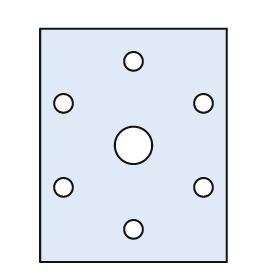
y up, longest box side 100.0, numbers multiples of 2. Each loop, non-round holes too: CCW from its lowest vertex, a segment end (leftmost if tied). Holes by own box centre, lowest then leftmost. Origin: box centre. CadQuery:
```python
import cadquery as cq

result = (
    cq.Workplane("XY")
    .moveTo(-40.0, -50.0)
    .lineTo(40.0, -50.0)
    .lineTo(40.0, 50.0)
    .lineTo(-40.0, 50.0)
    .close()
    .moveTo(0.0, -36.0)
    .circle(4.0)
    .moveTo(-30.0, -18.0)
    .circle(4.0)
    .moveTo(30.0, -18.0)
    .circle(4.0)
    .moveTo(0.0, 0.0)
    .circle(8.0)
    .moveTo(-30.0, 18.0)
    .circle(4.0)
    .moveTo(30.0, 18.0)
    .circle(4.0)
    .moveTo(0.0, 36.0)
    .circle(4.0)
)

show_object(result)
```